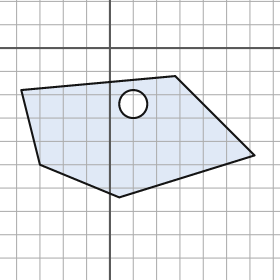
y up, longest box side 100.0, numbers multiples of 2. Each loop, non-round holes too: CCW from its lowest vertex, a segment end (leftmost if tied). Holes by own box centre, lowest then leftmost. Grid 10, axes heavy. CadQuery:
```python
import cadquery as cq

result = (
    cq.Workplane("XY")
    .moveTo(4.0, -64.0)
    .lineTo(62.0, -46.0)
    .lineTo(28.0, -12.0)
    .lineTo(-38.0, -18.0)
    .lineTo(-30.0, -50.0)
    .close()
    .moveTo(10.0, -24.0)
    .circle(6.0)
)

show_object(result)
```